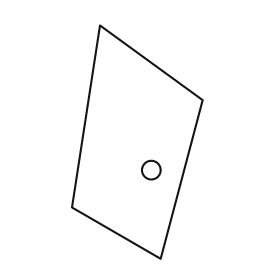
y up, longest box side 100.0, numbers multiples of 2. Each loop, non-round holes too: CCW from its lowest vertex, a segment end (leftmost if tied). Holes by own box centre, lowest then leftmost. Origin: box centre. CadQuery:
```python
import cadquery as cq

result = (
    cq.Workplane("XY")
    .moveTo(10.0, -50.0)
    .lineTo(28.0, 18.0)
    .lineTo(-16.0, 50.0)
    .lineTo(-28.0, -28.0)
    .close()
    .moveTo(6.0, -12.0)
    .circle(4.0)
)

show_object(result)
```